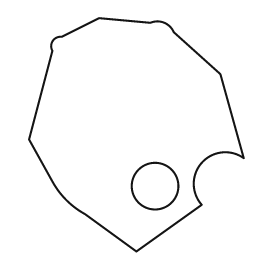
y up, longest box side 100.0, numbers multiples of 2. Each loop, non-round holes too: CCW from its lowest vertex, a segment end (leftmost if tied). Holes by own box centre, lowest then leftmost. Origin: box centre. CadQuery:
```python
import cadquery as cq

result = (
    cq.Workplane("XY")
    .moveTo(0.0, -50.0)
    .lineTo(28.0, -30.0)
    .threePointArc((28.0, -12.0), (46.0, -10.0))
    .lineTo(36.0, 26.0)
    .lineTo(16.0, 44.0)
    .threePointArc((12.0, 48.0), (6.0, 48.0))
    .lineTo(-16.0, 50.0)
    .lineTo(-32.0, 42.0)
    .threePointArc((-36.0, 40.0), (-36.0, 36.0))
    .lineTo(-46.0, -2.0)
    .lineTo(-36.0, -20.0)
    .threePointArc((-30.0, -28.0), (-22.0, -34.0))
    .close()
    .moveTo(8.0, -22.0)
    .circle(10.0)
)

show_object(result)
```